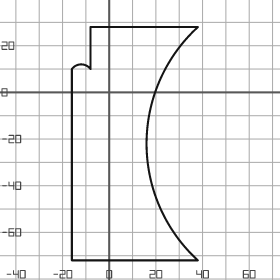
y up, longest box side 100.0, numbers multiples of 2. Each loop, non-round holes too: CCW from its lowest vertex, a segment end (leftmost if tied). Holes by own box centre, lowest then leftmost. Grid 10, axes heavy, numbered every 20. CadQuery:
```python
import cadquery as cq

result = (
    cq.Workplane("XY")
    .moveTo(-16.0, -72.0)
    .lineTo(38.0, -72.0)
    .threePointArc((16.0, -22.0), (38.0, 28.0))
    .lineTo(-8.0, 28.0)
    .lineTo(-8.0, 10.0)
    .threePointArc((-12.0, 12.0), (-16.0, 10.0))
    .close()
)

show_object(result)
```